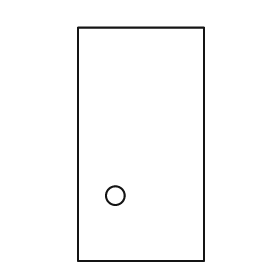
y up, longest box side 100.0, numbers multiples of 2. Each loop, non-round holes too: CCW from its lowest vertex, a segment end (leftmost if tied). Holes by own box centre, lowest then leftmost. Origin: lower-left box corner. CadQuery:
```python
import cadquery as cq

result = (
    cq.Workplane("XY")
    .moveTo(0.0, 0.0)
    .lineTo(54.0, 0.0)
    .lineTo(54.0, 100.0)
    .lineTo(0.0, 100.0)
    .close()
    .moveTo(16.0, 28.0)
    .circle(4.0)
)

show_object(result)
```